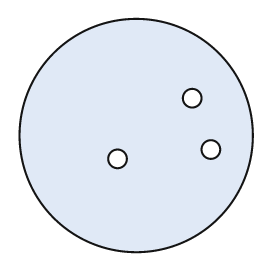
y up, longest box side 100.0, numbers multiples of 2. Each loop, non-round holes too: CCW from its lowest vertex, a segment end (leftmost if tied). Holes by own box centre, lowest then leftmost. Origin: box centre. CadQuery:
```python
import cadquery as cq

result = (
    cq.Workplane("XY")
    .moveTo(0.0, 0.0)
    .circle(50.0)
    .moveTo(-8.0, -10.0)
    .circle(4.0)
    .moveTo(32.0, -6.0)
    .circle(4.0)
    .moveTo(24.0, 16.0)
    .circle(4.0)
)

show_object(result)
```